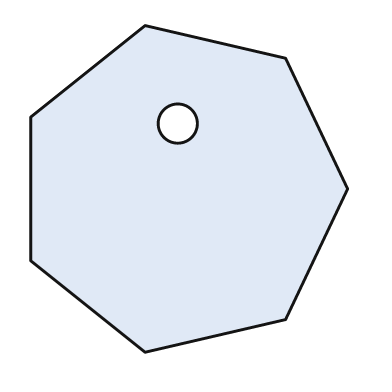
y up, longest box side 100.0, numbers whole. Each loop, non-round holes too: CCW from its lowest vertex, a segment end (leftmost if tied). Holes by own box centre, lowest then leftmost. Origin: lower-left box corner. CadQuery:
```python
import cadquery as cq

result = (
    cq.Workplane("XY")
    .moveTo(35.0, 0.0)
    .lineTo(78.0, 10.0)
    .lineTo(97.0, 50.0)
    .lineTo(78.0, 90.0)
    .lineTo(35.0, 100.0)
    .lineTo(0.0, 72.0)
    .lineTo(0.0, 28.0)
    .close()
    .moveTo(45.0, 70.0)
    .circle(6.0)
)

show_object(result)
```